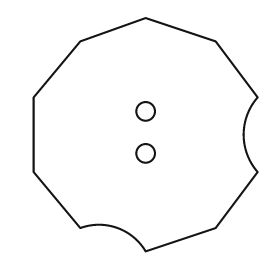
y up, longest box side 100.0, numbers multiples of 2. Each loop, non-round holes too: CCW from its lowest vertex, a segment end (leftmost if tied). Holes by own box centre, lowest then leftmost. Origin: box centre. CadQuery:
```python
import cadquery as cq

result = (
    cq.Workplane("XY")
    .moveTo(0.0, -50.0)
    .lineTo(30.0, -40.0)
    .lineTo(48.0, -16.0)
    .threePointArc((42.0, 0.0), (48.0, 16.0))
    .lineTo(30.0, 40.0)
    .lineTo(0.0, 50.0)
    .lineTo(-28.0, 40.0)
    .lineTo(-48.0, 16.0)
    .lineTo(-48.0, -16.0)
    .lineTo(-28.0, -40.0)
    .threePointArc((-12.0, -40.0), (0.0, -50.0))
    .close()
    .moveTo(0.0, -8.0)
    .circle(4.0)
    .moveTo(0.0, 10.0)
    .circle(4.0)
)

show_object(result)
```